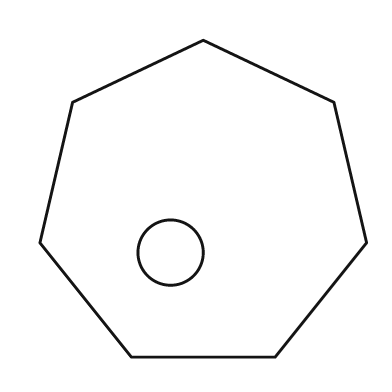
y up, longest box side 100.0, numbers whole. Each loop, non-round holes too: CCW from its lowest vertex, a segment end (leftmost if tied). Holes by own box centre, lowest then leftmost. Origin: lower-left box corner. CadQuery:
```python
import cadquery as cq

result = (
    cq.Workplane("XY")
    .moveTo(28.0, 0.0)
    .lineTo(72.0, 0.0)
    .lineTo(100.0, 35.0)
    .lineTo(90.0, 78.0)
    .lineTo(50.0, 97.0)
    .lineTo(10.0, 78.0)
    .lineTo(0.0, 35.0)
    .close()
    .moveTo(40.0, 32.0)
    .circle(10.0)
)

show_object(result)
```